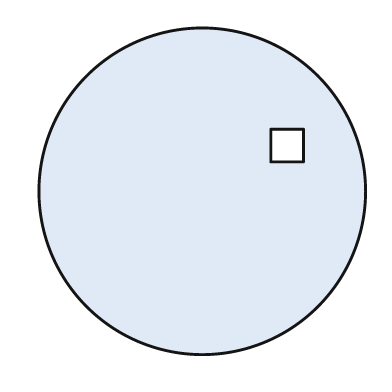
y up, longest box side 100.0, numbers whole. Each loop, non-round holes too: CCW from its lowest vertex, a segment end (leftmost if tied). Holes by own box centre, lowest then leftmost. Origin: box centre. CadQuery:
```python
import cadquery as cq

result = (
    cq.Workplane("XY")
    .moveTo(0.0, 0.0)
    .circle(50.0)
    .moveTo(21.0, 9.0)
    .lineTo(31.0, 9.0)
    .lineTo(31.0, 19.0)
    .lineTo(21.0, 19.0)
    .close()
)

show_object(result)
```